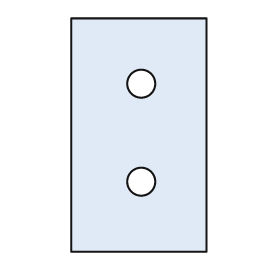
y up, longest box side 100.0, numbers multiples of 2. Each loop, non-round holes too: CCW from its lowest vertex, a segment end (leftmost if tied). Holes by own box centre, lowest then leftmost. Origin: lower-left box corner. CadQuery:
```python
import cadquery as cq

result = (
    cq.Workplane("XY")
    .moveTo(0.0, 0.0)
    .lineTo(58.0, 0.0)
    .lineTo(58.0, 100.0)
    .lineTo(0.0, 100.0)
    .close()
    .moveTo(30.0, 30.0)
    .circle(6.0)
    .moveTo(30.0, 72.0)
    .circle(6.0)
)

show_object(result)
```